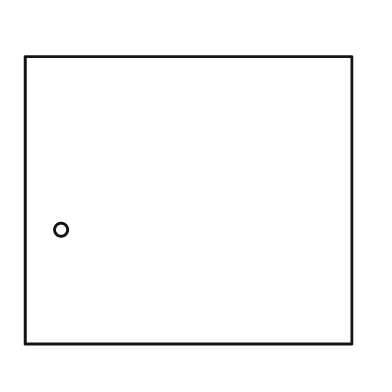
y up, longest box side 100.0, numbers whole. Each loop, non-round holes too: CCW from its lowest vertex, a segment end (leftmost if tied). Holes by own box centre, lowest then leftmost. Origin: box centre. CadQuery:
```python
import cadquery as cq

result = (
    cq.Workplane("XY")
    .moveTo(-50.0, -44.0)
    .lineTo(50.0, -44.0)
    .lineTo(50.0, 44.0)
    .lineTo(-50.0, 44.0)
    .close()
    .moveTo(-39.0, -9.0)
    .circle(2.0)
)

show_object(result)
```